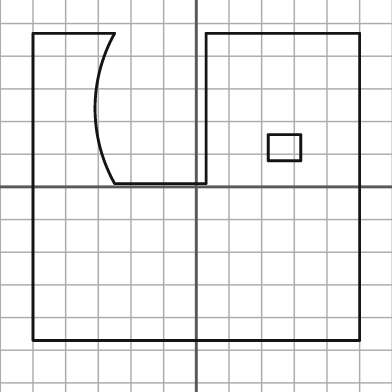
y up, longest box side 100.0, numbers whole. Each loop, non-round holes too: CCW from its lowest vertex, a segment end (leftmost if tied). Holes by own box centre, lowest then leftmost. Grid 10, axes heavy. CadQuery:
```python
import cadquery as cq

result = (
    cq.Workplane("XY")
    .moveTo(-50.0, -47.0)
    .lineTo(50.0, -47.0)
    .lineTo(50.0, 47.0)
    .lineTo(3.0, 47.0)
    .lineTo(3.0, 1.0)
    .lineTo(-25.0, 1.0)
    .threePointArc((-31.0, 24.0), (-25.0, 47.0))
    .lineTo(-50.0, 47.0)
    .close()
    .moveTo(22.0, 8.0)
    .lineTo(32.0, 8.0)
    .lineTo(32.0, 16.0)
    .lineTo(22.0, 16.0)
    .close()
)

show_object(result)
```